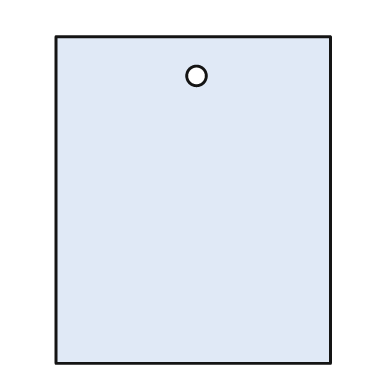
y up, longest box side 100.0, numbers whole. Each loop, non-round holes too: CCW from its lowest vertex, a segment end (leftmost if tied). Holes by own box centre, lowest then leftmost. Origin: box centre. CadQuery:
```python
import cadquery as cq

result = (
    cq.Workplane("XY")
    .moveTo(-42.0, -50.0)
    .lineTo(42.0, -50.0)
    .lineTo(42.0, 50.0)
    .lineTo(-42.0, 50.0)
    .close()
    .moveTo(1.0, 38.0)
    .circle(3.0)
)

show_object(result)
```